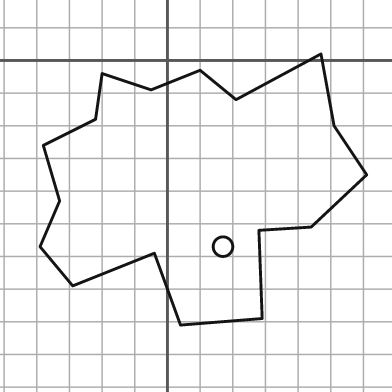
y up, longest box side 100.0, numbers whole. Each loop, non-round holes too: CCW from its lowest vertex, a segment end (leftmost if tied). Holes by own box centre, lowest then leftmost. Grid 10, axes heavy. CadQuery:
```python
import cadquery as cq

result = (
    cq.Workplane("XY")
    .moveTo(4.0, -81.0)
    .lineTo(29.0, -79.0)
    .lineTo(28.0, -52.0)
    .lineTo(44.0, -51.0)
    .lineTo(61.0, -35.0)
    .lineTo(51.0, -20.0)
    .lineTo(47.0, 2.0)
    .lineTo(21.0, -12.0)
    .lineTo(10.0, -3.0)
    .lineTo(-5.0, -9.0)
    .lineTo(-20.0, -4.0)
    .lineTo(-22.0, -18.0)
    .lineTo(-38.0, -26.0)
    .lineTo(-33.0, -43.0)
    .lineTo(-39.0, -57.0)
    .lineTo(-29.0, -69.0)
    .lineTo(-4.0, -59.0)
    .close()
    .moveTo(17.0, -57.0)
    .circle(3.0)
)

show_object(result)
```